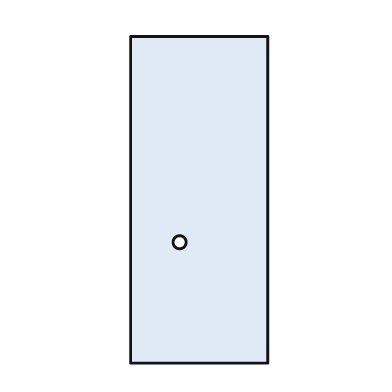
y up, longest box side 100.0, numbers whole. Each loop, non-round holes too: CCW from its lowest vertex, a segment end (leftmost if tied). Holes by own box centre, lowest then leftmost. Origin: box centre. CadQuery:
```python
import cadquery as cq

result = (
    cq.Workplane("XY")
    .moveTo(-21.0, -50.0)
    .lineTo(21.0, -50.0)
    .lineTo(21.0, 50.0)
    .lineTo(-21.0, 50.0)
    .close()
    .moveTo(-6.0, -13.0)
    .circle(2.0)
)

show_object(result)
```